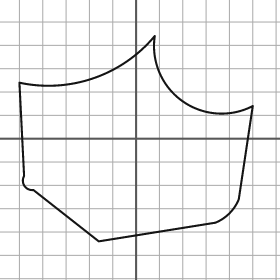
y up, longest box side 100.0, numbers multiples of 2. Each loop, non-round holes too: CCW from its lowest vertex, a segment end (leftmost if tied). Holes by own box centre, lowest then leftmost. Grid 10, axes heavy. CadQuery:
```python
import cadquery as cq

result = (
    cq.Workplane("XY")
    .moveTo(-16.0, -44.0)
    .lineTo(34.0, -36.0)
    .threePointArc((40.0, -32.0), (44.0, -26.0))
    .lineTo(50.0, 14.0)
    .threePointArc((20.0, 16.0), (8.0, 44.0))
    .threePointArc((-18.0, 26.0), (-50.0, 24.0))
    .lineTo(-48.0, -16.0)
    .threePointArc((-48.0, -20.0), (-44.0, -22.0))
    .close()
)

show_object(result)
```